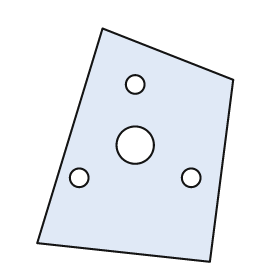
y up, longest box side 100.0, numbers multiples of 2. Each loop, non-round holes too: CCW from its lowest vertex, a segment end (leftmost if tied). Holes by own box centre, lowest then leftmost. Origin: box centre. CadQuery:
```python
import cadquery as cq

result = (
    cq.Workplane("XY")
    .moveTo(32.0, -50.0)
    .lineTo(42.0, 28.0)
    .lineTo(-14.0, 50.0)
    .lineTo(-42.0, -42.0)
    .close()
    .moveTo(-24.0, -14.0)
    .circle(4.0)
    .moveTo(24.0, -14.0)
    .circle(4.0)
    .moveTo(0.0, 0.0)
    .circle(8.0)
    .moveTo(0.0, 26.0)
    .circle(4.0)
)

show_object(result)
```